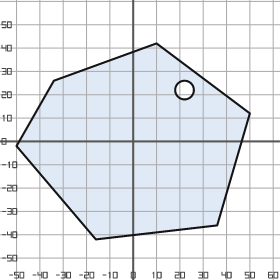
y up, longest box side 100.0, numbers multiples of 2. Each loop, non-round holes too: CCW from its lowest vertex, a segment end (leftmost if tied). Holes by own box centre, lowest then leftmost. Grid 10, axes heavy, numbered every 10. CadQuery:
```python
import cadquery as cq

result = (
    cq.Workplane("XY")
    .moveTo(-16.0, -42.0)
    .lineTo(36.0, -36.0)
    .lineTo(50.0, 12.0)
    .lineTo(10.0, 42.0)
    .lineTo(-34.0, 26.0)
    .lineTo(-50.0, -2.0)
    .close()
    .moveTo(22.0, 22.0)
    .circle(4.0)
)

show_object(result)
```